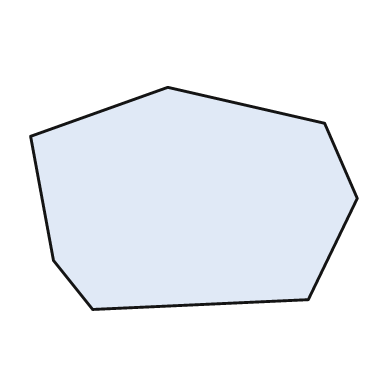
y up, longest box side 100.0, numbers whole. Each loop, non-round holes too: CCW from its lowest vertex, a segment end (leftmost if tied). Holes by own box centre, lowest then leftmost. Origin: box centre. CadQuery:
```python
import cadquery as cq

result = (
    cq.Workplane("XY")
    .moveTo(-31.0, -34.0)
    .lineTo(35.0, -31.0)
    .lineTo(50.0, 0.0)
    .lineTo(40.0, 23.0)
    .lineTo(-8.0, 34.0)
    .lineTo(-50.0, 19.0)
    .lineTo(-43.0, -19.0)
    .close()
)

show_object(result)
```